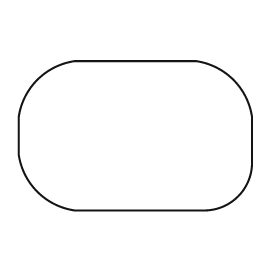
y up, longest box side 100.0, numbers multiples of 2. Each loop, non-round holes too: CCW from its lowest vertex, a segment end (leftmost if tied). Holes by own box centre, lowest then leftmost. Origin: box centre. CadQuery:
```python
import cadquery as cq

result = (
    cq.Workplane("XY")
    .moveTo(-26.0, -32.0)
    .lineTo(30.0, -32.0)
    .threePointArc((44.0, -26.0), (50.0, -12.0))
    .lineTo(50.0, 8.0)
    .threePointArc((42.0, 24.0), (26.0, 32.0))
    .lineTo(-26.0, 32.0)
    .threePointArc((-42.0, 24.0), (-50.0, 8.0))
    .lineTo(-50.0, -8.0)
    .threePointArc((-42.0, -24.0), (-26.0, -32.0))
    .close()
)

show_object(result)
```